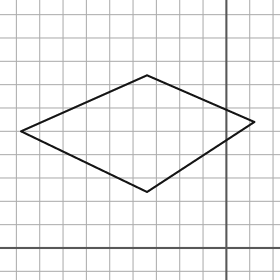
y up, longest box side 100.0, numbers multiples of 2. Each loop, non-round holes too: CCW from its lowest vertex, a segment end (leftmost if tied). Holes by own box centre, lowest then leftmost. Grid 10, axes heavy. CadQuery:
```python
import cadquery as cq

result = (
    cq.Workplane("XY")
    .moveTo(-34.0, 24.0)
    .lineTo(12.0, 54.0)
    .lineTo(-34.0, 74.0)
    .lineTo(-88.0, 50.0)
    .close()
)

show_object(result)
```